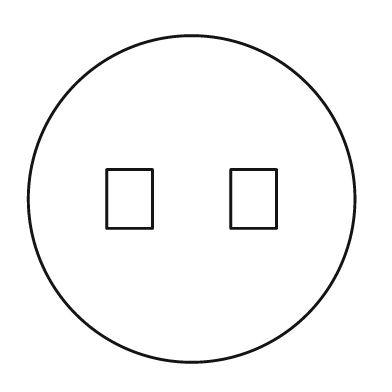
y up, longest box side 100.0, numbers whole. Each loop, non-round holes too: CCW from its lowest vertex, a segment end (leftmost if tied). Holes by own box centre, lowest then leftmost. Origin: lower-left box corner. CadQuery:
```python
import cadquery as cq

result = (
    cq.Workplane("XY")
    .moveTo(50.0, 50.0)
    .circle(50.0)
    .moveTo(24.0, 41.0)
    .lineTo(38.0, 41.0)
    .lineTo(38.0, 59.0)
    .lineTo(24.0, 59.0)
    .close()
    .moveTo(62.0, 41.0)
    .lineTo(76.0, 41.0)
    .lineTo(76.0, 59.0)
    .lineTo(62.0, 59.0)
    .close()
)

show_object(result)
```